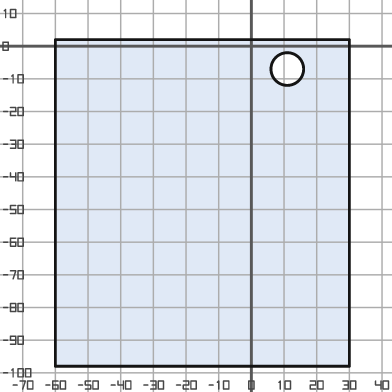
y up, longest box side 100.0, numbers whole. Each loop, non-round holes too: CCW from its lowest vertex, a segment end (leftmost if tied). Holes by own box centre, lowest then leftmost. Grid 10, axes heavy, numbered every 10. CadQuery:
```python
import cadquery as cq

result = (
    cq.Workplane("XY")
    .moveTo(-60.0, -98.0)
    .lineTo(30.0, -98.0)
    .lineTo(30.0, 2.0)
    .lineTo(-60.0, 2.0)
    .close()
    .moveTo(11.0, -7.0)
    .circle(5.0)
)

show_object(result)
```